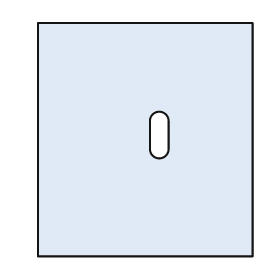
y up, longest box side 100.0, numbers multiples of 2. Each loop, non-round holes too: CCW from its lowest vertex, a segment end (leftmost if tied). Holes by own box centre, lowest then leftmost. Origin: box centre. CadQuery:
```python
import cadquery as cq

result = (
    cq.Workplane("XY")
    .moveTo(-46.0, -50.0)
    .lineTo(46.0, -50.0)
    .lineTo(46.0, 50.0)
    .lineTo(-46.0, 50.0)
    .close()
    .moveTo(2.0, -4.0)
    .threePointArc((6.0, -8.0), (10.0, -4.0))
    .lineTo(10.0, 8.0)
    .threePointArc((6.0, 12.0), (2.0, 8.0))
    .close()
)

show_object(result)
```